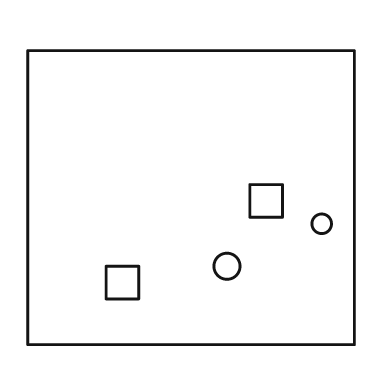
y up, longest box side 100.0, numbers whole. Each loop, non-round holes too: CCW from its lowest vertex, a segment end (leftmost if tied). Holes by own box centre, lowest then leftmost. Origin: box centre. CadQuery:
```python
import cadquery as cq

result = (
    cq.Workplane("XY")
    .moveTo(-50.0, -45.0)
    .lineTo(50.0, -45.0)
    .lineTo(50.0, 45.0)
    .lineTo(-50.0, 45.0)
    .close()
    .moveTo(-26.0, -31.0)
    .lineTo(-16.0, -31.0)
    .lineTo(-16.0, -21.0)
    .lineTo(-26.0, -21.0)
    .close()
    .moveTo(11.0, -21.0)
    .circle(4.0)
    .moveTo(40.0, -8.0)
    .circle(3.0)
    .moveTo(18.0, -6.0)
    .lineTo(28.0, -6.0)
    .lineTo(28.0, 4.0)
    .lineTo(18.0, 4.0)
    .close()
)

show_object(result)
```